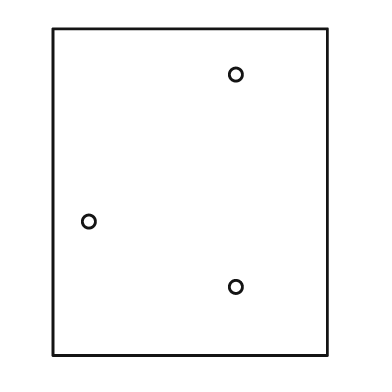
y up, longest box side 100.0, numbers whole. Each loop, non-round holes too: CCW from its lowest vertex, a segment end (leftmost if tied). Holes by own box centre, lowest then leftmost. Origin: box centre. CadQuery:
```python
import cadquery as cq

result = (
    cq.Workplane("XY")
    .moveTo(-42.0, -50.0)
    .lineTo(42.0, -50.0)
    .lineTo(42.0, 50.0)
    .lineTo(-42.0, 50.0)
    .close()
    .moveTo(14.0, -29.0)
    .circle(2.0)
    .moveTo(-31.0, -9.0)
    .circle(2.0)
    .moveTo(14.0, 36.0)
    .circle(2.0)
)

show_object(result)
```